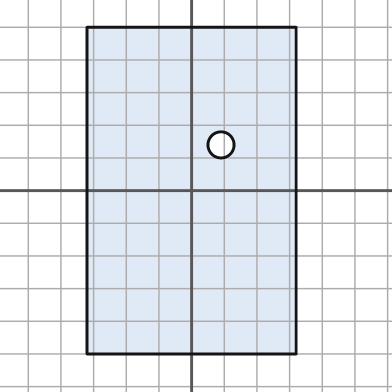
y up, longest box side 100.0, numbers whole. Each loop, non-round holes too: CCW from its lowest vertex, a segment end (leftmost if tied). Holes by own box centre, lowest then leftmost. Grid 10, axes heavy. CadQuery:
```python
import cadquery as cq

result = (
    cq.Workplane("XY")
    .moveTo(-32.0, -50.0)
    .lineTo(32.0, -50.0)
    .lineTo(32.0, 50.0)
    .lineTo(-32.0, 50.0)
    .close()
    .moveTo(9.0, 14.0)
    .circle(4.0)
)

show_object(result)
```